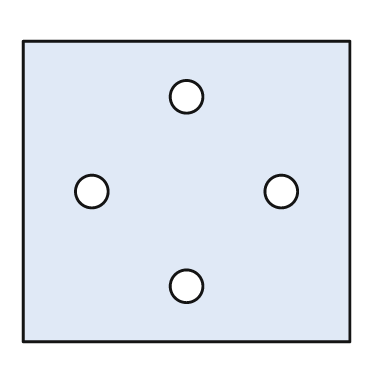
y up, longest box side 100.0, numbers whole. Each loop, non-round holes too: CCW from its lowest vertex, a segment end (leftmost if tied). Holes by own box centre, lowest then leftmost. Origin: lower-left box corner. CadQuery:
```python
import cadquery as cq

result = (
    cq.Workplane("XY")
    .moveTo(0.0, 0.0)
    .lineTo(100.0, 0.0)
    .lineTo(100.0, 92.0)
    .lineTo(0.0, 92.0)
    .close()
    .moveTo(50.0, 17.0)
    .circle(5.0)
    .moveTo(21.0, 46.0)
    .circle(5.0)
    .moveTo(79.0, 46.0)
    .circle(5.0)
    .moveTo(50.0, 75.0)
    .circle(5.0)
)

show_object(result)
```